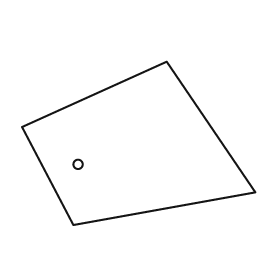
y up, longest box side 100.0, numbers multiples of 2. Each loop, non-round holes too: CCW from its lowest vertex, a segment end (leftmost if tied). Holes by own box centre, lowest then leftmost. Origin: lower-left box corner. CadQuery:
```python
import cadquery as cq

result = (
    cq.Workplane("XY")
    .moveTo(22.0, 0.0)
    .lineTo(100.0, 14.0)
    .lineTo(62.0, 70.0)
    .lineTo(0.0, 42.0)
    .close()
    .moveTo(24.0, 26.0)
    .circle(2.0)
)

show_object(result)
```